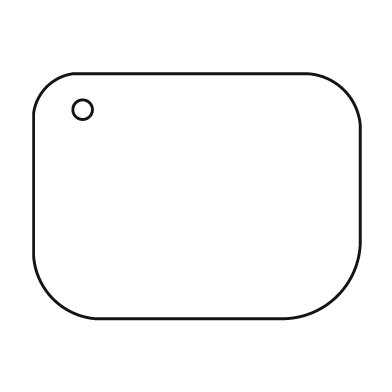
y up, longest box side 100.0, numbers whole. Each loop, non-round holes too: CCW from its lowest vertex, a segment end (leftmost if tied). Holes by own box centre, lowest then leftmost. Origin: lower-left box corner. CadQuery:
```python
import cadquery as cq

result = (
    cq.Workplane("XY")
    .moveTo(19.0, 0.0)
    .lineTo(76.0, 0.0)
    .threePointArc((93.0, 7.0), (100.0, 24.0))
    .lineTo(100.0, 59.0)
    .threePointArc((95.0, 70.0), (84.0, 75.0))
    .lineTo(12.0, 75.0)
    .threePointArc((4.0, 71.0), (0.0, 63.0))
    .lineTo(0.0, 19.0)
    .threePointArc((6.0, 6.0), (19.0, 0.0))
    .close()
    .moveTo(15.0, 64.0)
    .circle(3.0)
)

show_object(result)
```